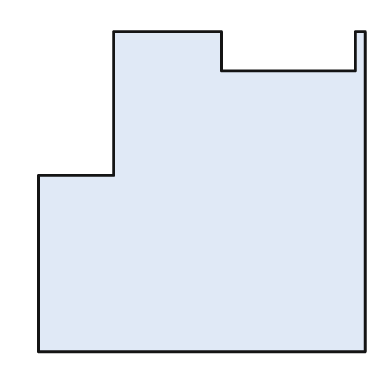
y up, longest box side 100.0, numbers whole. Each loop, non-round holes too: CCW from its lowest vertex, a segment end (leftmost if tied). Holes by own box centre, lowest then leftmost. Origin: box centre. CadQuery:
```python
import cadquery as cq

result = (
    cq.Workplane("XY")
    .moveTo(-50.0, -49.0)
    .lineTo(50.0, -49.0)
    .lineTo(50.0, 49.0)
    .lineTo(47.0, 49.0)
    .lineTo(47.0, 37.0)
    .lineTo(6.0, 37.0)
    .lineTo(6.0, 49.0)
    .lineTo(-27.0, 49.0)
    .lineTo(-27.0, 5.0)
    .lineTo(-50.0, 5.0)
    .close()
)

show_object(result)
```